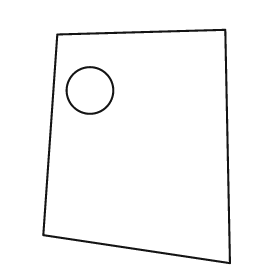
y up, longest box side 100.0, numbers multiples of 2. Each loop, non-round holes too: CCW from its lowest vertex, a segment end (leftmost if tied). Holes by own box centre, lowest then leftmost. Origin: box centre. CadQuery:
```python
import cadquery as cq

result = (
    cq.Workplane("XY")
    .moveTo(40.0, -50.0)
    .lineTo(38.0, 50.0)
    .lineTo(-34.0, 48.0)
    .lineTo(-40.0, -38.0)
    .close()
    .moveTo(-20.0, 24.0)
    .circle(10.0)
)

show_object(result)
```